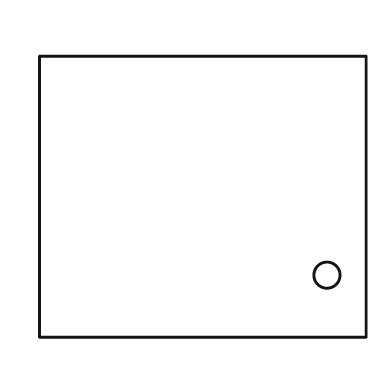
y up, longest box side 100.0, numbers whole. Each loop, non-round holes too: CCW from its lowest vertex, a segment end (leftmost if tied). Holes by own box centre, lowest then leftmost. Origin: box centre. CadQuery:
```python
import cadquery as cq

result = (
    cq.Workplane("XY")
    .moveTo(-50.0, -43.0)
    .lineTo(50.0, -43.0)
    .lineTo(50.0, 43.0)
    .lineTo(-50.0, 43.0)
    .close()
    .moveTo(38.0, -24.0)
    .circle(4.0)
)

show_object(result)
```